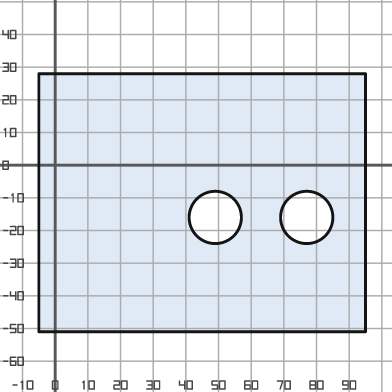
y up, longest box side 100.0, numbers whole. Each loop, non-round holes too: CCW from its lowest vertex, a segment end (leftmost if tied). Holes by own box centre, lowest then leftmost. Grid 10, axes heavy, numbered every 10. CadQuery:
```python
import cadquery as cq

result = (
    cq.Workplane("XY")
    .moveTo(-5.0, -51.0)
    .lineTo(95.0, -51.0)
    .lineTo(95.0, 28.0)
    .lineTo(-5.0, 28.0)
    .close()
    .moveTo(49.0, -16.0)
    .circle(8.0)
    .moveTo(77.0, -16.0)
    .circle(8.0)
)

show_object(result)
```